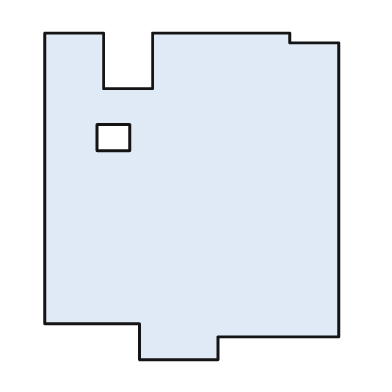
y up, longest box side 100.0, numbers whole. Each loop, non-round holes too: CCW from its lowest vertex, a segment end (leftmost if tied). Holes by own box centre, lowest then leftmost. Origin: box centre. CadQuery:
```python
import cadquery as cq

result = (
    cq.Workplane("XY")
    .moveTo(-16.0, -50.0)
    .lineTo(8.0, -50.0)
    .lineTo(8.0, -43.0)
    .lineTo(45.0, -43.0)
    .lineTo(45.0, 47.0)
    .lineTo(30.0, 47.0)
    .lineTo(30.0, 50.0)
    .lineTo(-12.0, 50.0)
    .lineTo(-12.0, 33.0)
    .lineTo(-27.0, 33.0)
    .lineTo(-27.0, 50.0)
    .lineTo(-45.0, 50.0)
    .lineTo(-45.0, -39.0)
    .lineTo(-16.0, -39.0)
    .close()
    .moveTo(-29.0, 14.0)
    .lineTo(-19.0, 14.0)
    .lineTo(-19.0, 22.0)
    .lineTo(-29.0, 22.0)
    .close()
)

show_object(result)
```